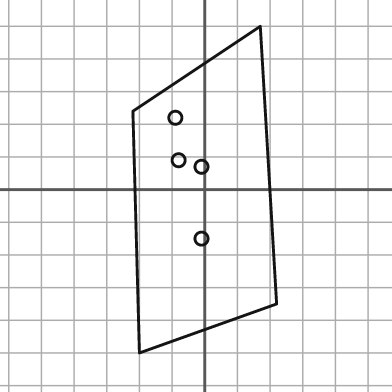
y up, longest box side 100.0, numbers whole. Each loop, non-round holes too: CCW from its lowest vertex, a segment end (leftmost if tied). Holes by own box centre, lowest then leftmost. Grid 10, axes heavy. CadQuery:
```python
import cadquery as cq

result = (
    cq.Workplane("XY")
    .moveTo(-20.0, -50.0)
    .lineTo(22.0, -35.0)
    .lineTo(17.0, 50.0)
    .lineTo(-22.0, 24.0)
    .close()
    .moveTo(-1.0, -15.0)
    .circle(2.0)
    .moveTo(-1.0, 7.0)
    .circle(2.0)
    .moveTo(-8.0, 9.0)
    .circle(2.0)
    .moveTo(-9.0, 22.0)
    .circle(2.0)
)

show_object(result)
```